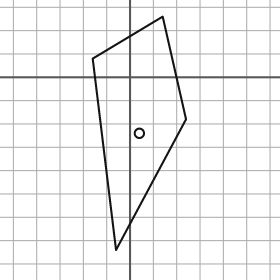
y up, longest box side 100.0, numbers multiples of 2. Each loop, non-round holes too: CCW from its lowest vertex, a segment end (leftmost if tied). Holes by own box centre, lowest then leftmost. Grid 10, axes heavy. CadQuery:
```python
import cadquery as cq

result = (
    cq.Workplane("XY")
    .moveTo(-6.0, -74.0)
    .lineTo(24.0, -18.0)
    .lineTo(14.0, 26.0)
    .lineTo(-16.0, 8.0)
    .close()
    .moveTo(4.0, -24.0)
    .circle(2.0)
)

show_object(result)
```